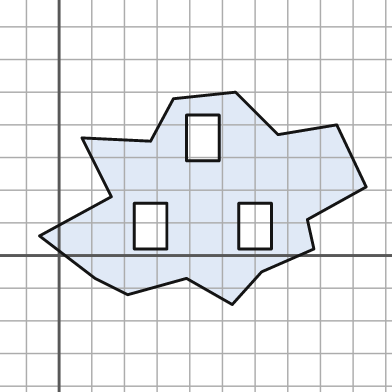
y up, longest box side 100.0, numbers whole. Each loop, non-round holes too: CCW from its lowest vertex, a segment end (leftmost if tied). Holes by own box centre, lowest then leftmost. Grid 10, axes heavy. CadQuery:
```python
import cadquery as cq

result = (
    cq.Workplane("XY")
    .moveTo(53.0, -15.0)
    .lineTo(62.0, -5.0)
    .lineTo(78.0, 2.0)
    .lineTo(76.0, 11.0)
    .lineTo(94.0, 21.0)
    .lineTo(85.0, 40.0)
    .lineTo(67.0, 37.0)
    .lineTo(54.0, 50.0)
    .lineTo(35.0, 48.0)
    .lineTo(28.0, 35.0)
    .lineTo(7.0, 36.0)
    .lineTo(16.0, 18.0)
    .lineTo(-6.0, 6.0)
    .lineTo(11.0, -7.0)
    .lineTo(21.0, -12.0)
    .lineTo(39.0, -7.0)
    .close()
    .moveTo(23.0, 2.0)
    .lineTo(33.0, 2.0)
    .lineTo(33.0, 16.0)
    .lineTo(23.0, 16.0)
    .close()
    .moveTo(55.0, 2.0)
    .lineTo(65.0, 2.0)
    .lineTo(65.0, 16.0)
    .lineTo(55.0, 16.0)
    .close()
    .moveTo(39.0, 29.0)
    .lineTo(49.0, 29.0)
    .lineTo(49.0, 43.0)
    .lineTo(39.0, 43.0)
    .close()
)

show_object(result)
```